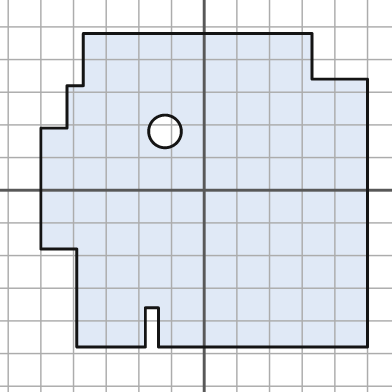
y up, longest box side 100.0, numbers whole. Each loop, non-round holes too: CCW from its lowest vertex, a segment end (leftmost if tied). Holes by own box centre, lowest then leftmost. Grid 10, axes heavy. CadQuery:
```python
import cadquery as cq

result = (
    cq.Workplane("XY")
    .moveTo(-39.0, -48.0)
    .lineTo(-18.0, -48.0)
    .lineTo(-18.0, -36.0)
    .lineTo(-14.0, -36.0)
    .lineTo(-14.0, -48.0)
    .lineTo(50.0, -48.0)
    .lineTo(50.0, 34.0)
    .lineTo(33.0, 34.0)
    .lineTo(33.0, 48.0)
    .lineTo(-37.0, 48.0)
    .lineTo(-37.0, 32.0)
    .lineTo(-42.0, 32.0)
    .lineTo(-42.0, 19.0)
    .lineTo(-50.0, 19.0)
    .lineTo(-50.0, -18.0)
    .lineTo(-39.0, -18.0)
    .close()
    .moveTo(-12.0, 18.0)
    .circle(5.0)
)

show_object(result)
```